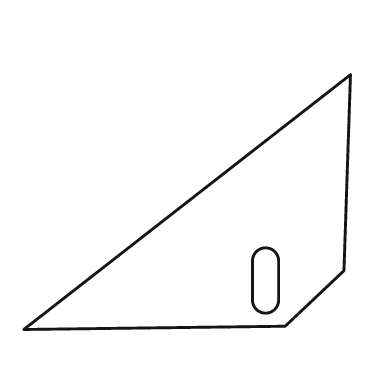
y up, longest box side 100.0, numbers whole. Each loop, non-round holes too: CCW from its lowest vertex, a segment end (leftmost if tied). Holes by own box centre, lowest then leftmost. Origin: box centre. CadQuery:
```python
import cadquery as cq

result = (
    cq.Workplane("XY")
    .moveTo(-50.0, -39.0)
    .lineTo(30.0, -38.0)
    .lineTo(48.0, -21.0)
    .lineTo(50.0, 39.0)
    .close()
    .moveTo(20.0, -30.0)
    .threePointArc((24.0, -34.0), (28.0, -30.0))
    .lineTo(28.0, -18.0)
    .threePointArc((24.0, -14.0), (20.0, -18.0))
    .close()
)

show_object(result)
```